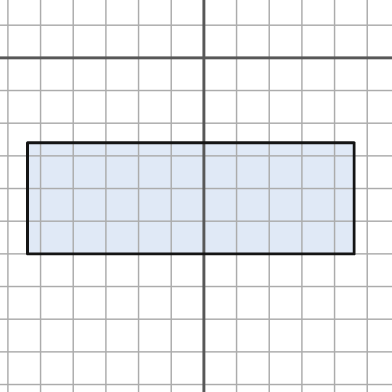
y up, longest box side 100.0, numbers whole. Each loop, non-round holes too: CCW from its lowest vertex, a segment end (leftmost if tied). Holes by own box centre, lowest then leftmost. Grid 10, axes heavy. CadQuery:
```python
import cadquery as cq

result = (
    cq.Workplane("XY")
    .moveTo(-54.0, -60.0)
    .lineTo(46.0, -60.0)
    .lineTo(46.0, -26.0)
    .lineTo(-54.0, -26.0)
    .close()
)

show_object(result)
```